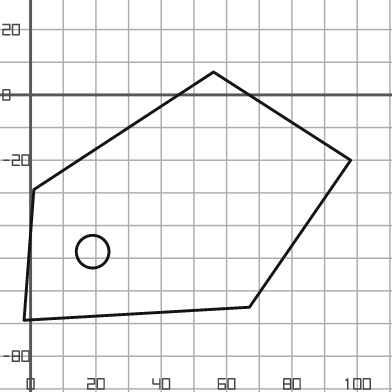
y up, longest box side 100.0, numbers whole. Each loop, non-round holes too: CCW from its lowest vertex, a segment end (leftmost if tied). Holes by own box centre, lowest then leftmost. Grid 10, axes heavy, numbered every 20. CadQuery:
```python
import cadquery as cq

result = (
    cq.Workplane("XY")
    .moveTo(-2.0, -69.0)
    .lineTo(67.0, -65.0)
    .lineTo(98.0, -20.0)
    .lineTo(56.0, 7.0)
    .lineTo(1.0, -29.0)
    .close()
    .moveTo(19.0, -48.0)
    .circle(5.0)
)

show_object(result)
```